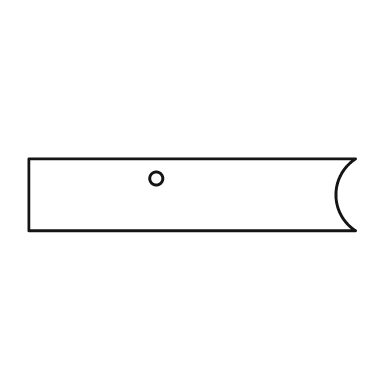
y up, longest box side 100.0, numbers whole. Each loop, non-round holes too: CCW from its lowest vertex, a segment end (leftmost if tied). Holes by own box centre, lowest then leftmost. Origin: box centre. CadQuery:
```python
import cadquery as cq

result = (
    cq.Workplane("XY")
    .moveTo(-50.0, -11.0)
    .lineTo(50.0, -11.0)
    .threePointArc((44.0, 0.0), (50.0, 11.0))
    .lineTo(-50.0, 11.0)
    .close()
    .moveTo(-11.0, 5.0)
    .circle(2.0)
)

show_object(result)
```